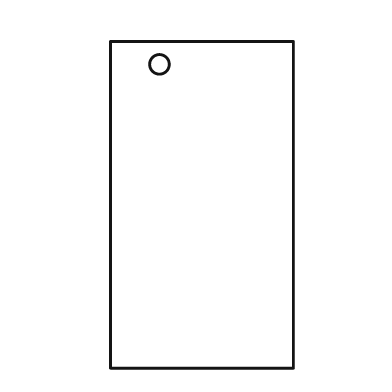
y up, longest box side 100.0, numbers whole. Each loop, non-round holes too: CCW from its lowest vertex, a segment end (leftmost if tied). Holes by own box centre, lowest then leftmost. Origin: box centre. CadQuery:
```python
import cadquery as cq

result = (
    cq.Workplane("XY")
    .moveTo(-28.0, -50.0)
    .lineTo(28.0, -50.0)
    .lineTo(28.0, 50.0)
    .lineTo(-28.0, 50.0)
    .close()
    .moveTo(-13.0, 43.0)
    .circle(3.0)
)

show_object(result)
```